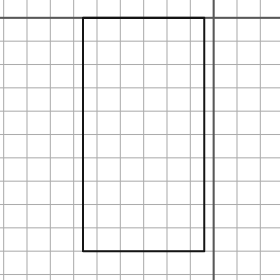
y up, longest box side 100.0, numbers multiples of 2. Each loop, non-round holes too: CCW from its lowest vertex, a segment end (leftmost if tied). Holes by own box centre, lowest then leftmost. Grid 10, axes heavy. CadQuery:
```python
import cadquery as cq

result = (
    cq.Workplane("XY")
    .moveTo(-56.0, -100.0)
    .lineTo(-4.0, -100.0)
    .lineTo(-4.0, 0.0)
    .lineTo(-56.0, 0.0)
    .close()
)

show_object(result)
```